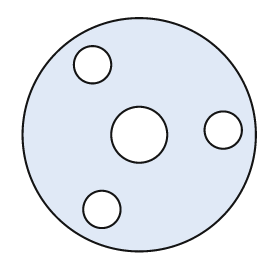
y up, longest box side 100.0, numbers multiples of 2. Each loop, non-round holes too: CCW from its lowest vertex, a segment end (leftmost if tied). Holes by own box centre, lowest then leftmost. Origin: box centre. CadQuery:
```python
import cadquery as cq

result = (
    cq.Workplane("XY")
    .moveTo(0.0, 0.0)
    .circle(50.0)
    .moveTo(-16.0, -32.0)
    .circle(8.0)
    .moveTo(0.0, 0.0)
    .circle(12.0)
    .moveTo(36.0, 2.0)
    .circle(8.0)
    .moveTo(-20.0, 30.0)
    .circle(8.0)
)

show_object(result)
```